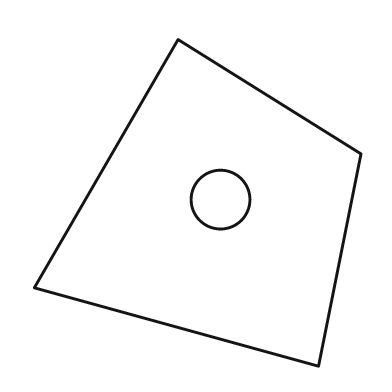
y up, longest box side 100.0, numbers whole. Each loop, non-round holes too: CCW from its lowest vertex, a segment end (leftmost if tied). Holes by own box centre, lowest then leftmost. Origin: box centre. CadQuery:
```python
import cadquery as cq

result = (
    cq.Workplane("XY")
    .moveTo(37.0, -50.0)
    .lineTo(50.0, 15.0)
    .lineTo(-6.0, 50.0)
    .lineTo(-50.0, -26.0)
    .close()
    .moveTo(7.0, 1.0)
    .circle(9.0)
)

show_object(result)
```